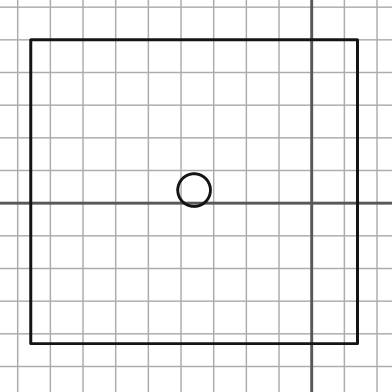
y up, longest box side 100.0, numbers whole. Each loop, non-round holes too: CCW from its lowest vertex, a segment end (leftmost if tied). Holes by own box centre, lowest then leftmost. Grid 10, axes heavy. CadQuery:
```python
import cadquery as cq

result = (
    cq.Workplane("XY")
    .moveTo(-86.0, -43.0)
    .lineTo(14.0, -43.0)
    .lineTo(14.0, 50.0)
    .lineTo(-86.0, 50.0)
    .close()
    .moveTo(-36.0, 4.0)
    .circle(5.0)
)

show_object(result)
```